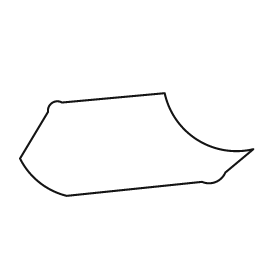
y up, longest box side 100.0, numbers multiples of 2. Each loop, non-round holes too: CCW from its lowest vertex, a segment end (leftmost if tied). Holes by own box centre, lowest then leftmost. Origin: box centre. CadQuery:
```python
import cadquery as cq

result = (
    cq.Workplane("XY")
    .moveTo(-30.0, -22.0)
    .lineTo(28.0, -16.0)
    .threePointArc((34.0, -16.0), (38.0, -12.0))
    .lineTo(50.0, -2.0)
    .threePointArc((26.0, 2.0), (12.0, 22.0))
    .lineTo(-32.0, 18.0)
    .threePointArc((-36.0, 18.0), (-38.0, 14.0))
    .lineTo(-50.0, -6.0)
    .threePointArc((-42.0, -16.0), (-30.0, -22.0))
    .close()
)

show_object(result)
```